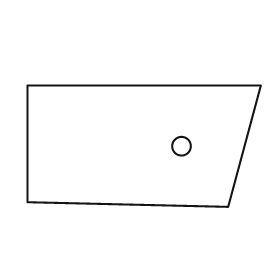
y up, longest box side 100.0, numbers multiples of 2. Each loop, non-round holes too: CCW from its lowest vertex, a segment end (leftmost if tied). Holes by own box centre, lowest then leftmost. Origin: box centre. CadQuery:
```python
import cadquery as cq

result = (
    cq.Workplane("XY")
    .moveTo(36.0, -26.0)
    .lineTo(50.0, 26.0)
    .lineTo(-50.0, 26.0)
    .lineTo(-50.0, -24.0)
    .close()
    .moveTo(16.0, 0.0)
    .circle(4.0)
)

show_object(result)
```